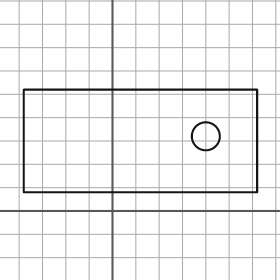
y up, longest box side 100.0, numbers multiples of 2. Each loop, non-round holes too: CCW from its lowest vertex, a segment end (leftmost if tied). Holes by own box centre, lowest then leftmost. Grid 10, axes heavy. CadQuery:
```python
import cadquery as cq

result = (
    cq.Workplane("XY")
    .moveTo(-38.0, 8.0)
    .lineTo(62.0, 8.0)
    .lineTo(62.0, 52.0)
    .lineTo(-38.0, 52.0)
    .close()
    .moveTo(40.0, 32.0)
    .circle(6.0)
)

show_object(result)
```